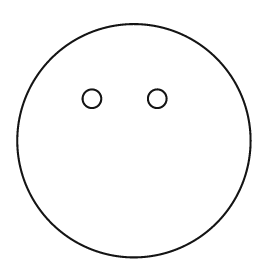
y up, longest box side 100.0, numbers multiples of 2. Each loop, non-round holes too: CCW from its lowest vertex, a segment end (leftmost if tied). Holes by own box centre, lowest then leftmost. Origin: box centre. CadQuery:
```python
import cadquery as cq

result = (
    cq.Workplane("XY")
    .moveTo(0.0, 0.0)
    .circle(50.0)
    .moveTo(-18.0, 18.0)
    .circle(4.0)
    .moveTo(10.0, 18.0)
    .circle(4.0)
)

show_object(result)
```